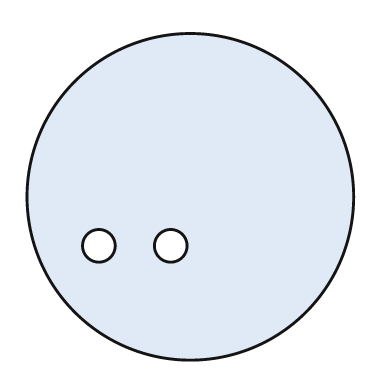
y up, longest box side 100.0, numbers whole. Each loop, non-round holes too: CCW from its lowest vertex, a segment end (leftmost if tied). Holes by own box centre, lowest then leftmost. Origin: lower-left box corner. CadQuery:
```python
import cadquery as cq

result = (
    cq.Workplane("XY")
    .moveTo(50.0, 50.0)
    .circle(50.0)
    .moveTo(22.0, 35.0)
    .circle(5.0)
    .moveTo(44.0, 35.0)
    .circle(5.0)
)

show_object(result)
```